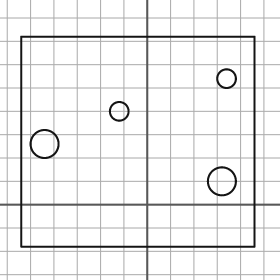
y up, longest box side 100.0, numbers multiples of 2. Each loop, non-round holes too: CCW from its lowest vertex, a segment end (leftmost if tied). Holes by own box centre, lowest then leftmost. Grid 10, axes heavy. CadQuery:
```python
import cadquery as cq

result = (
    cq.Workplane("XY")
    .moveTo(-54.0, -18.0)
    .lineTo(46.0, -18.0)
    .lineTo(46.0, 72.0)
    .lineTo(-54.0, 72.0)
    .close()
    .moveTo(32.0, 10.0)
    .circle(6.0)
    .moveTo(-44.0, 26.0)
    .circle(6.0)
    .moveTo(-12.0, 40.0)
    .circle(4.0)
    .moveTo(34.0, 54.0)
    .circle(4.0)
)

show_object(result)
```